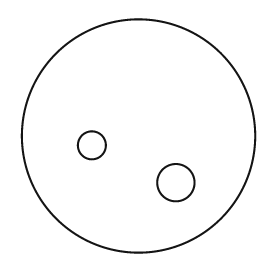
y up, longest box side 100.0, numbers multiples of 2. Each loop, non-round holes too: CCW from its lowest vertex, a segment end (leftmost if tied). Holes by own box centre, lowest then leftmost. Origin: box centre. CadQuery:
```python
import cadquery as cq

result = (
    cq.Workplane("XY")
    .moveTo(0.0, 0.0)
    .circle(50.0)
    .moveTo(16.0, -20.0)
    .circle(8.0)
    .moveTo(-20.0, -4.0)
    .circle(6.0)
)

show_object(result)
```